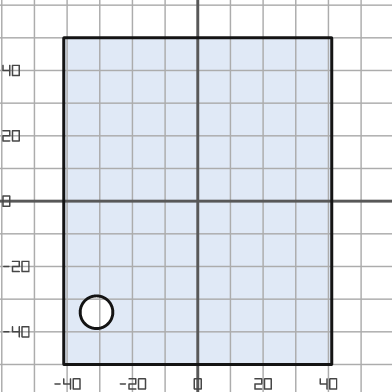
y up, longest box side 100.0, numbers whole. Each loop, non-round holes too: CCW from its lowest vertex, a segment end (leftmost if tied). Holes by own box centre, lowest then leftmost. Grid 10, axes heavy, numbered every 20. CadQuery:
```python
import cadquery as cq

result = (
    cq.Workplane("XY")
    .moveTo(-41.0, -50.0)
    .lineTo(41.0, -50.0)
    .lineTo(41.0, 50.0)
    .lineTo(-41.0, 50.0)
    .close()
    .moveTo(-31.0, -34.0)
    .circle(5.0)
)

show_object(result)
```